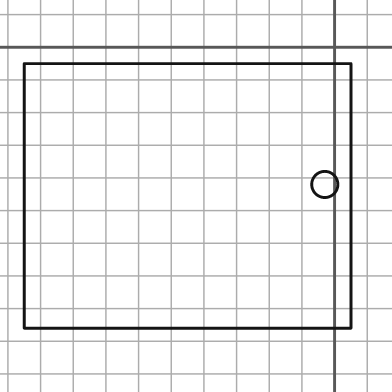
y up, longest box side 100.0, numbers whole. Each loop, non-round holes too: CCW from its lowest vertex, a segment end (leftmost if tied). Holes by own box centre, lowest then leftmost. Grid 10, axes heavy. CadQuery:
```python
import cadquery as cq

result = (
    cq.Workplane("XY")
    .moveTo(-95.0, -86.0)
    .lineTo(5.0, -86.0)
    .lineTo(5.0, -5.0)
    .lineTo(-95.0, -5.0)
    .close()
    .moveTo(-3.0, -42.0)
    .circle(4.0)
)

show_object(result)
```